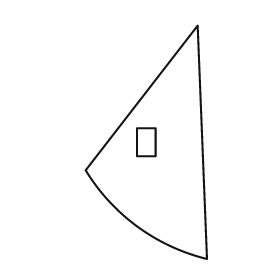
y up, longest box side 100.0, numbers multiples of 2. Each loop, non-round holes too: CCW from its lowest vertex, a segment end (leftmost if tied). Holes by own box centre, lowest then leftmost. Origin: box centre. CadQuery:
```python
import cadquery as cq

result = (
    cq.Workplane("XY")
    .moveTo(26.0, -50.0)
    .lineTo(22.0, 50.0)
    .lineTo(-26.0, -12.0)
    .threePointArc((-4.0, -36.0), (26.0, -50.0))
    .close()
    .moveTo(-4.0, -6.0)
    .lineTo(4.0, -6.0)
    .lineTo(4.0, 6.0)
    .lineTo(-4.0, 6.0)
    .close()
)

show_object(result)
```